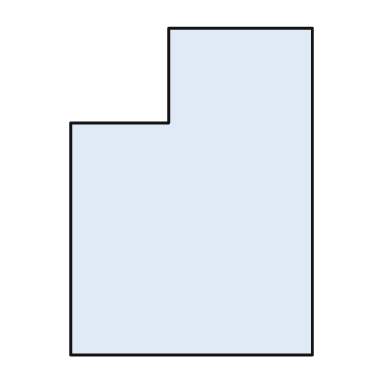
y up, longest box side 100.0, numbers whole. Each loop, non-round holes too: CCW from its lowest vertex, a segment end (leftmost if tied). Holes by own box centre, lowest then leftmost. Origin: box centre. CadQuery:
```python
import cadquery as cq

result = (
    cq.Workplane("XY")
    .moveTo(-37.0, -50.0)
    .lineTo(37.0, -50.0)
    .lineTo(37.0, 50.0)
    .lineTo(-7.0, 50.0)
    .lineTo(-7.0, 21.0)
    .lineTo(-37.0, 21.0)
    .close()
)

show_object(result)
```